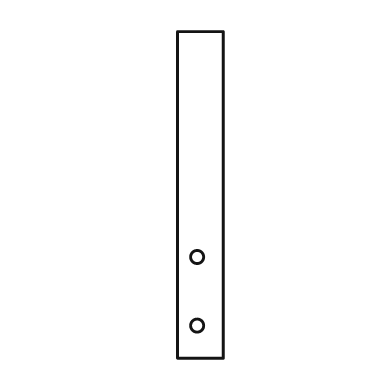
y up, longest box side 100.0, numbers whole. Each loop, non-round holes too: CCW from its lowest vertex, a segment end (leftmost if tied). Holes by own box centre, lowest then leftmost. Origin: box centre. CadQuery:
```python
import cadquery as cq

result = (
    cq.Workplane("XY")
    .moveTo(-7.0, -50.0)
    .lineTo(7.0, -50.0)
    .lineTo(7.0, 50.0)
    .lineTo(-7.0, 50.0)
    .close()
    .moveTo(-1.0, -40.0)
    .circle(2.0)
    .moveTo(-1.0, -19.0)
    .circle(2.0)
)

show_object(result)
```